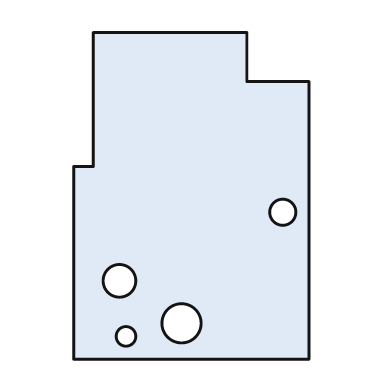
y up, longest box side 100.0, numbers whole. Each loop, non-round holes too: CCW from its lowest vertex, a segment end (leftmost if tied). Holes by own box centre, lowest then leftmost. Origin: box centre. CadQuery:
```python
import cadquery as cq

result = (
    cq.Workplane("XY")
    .moveTo(-36.0, -50.0)
    .lineTo(36.0, -50.0)
    .lineTo(36.0, 35.0)
    .lineTo(17.0, 35.0)
    .lineTo(17.0, 50.0)
    .lineTo(-30.0, 50.0)
    .lineTo(-30.0, 9.0)
    .lineTo(-36.0, 9.0)
    .close()
    .moveTo(-20.0, -43.0)
    .circle(3.0)
    .moveTo(-3.0, -39.0)
    .circle(6.0)
    .moveTo(-22.0, -26.0)
    .circle(5.0)
    .moveTo(28.0, -5.0)
    .circle(4.0)
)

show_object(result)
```